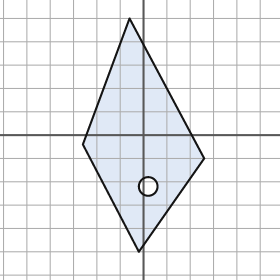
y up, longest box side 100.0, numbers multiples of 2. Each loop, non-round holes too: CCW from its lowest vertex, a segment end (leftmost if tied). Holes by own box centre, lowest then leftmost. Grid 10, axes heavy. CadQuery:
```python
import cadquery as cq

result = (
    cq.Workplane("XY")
    .moveTo(-2.0, -50.0)
    .lineTo(26.0, -10.0)
    .lineTo(-6.0, 50.0)
    .lineTo(-26.0, -4.0)
    .close()
    .moveTo(2.0, -22.0)
    .circle(4.0)
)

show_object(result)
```